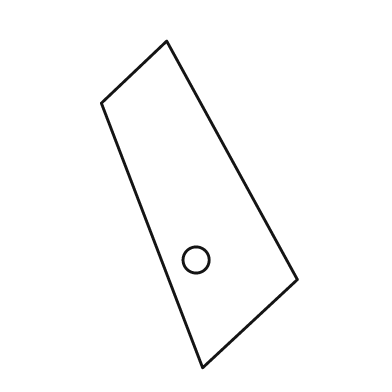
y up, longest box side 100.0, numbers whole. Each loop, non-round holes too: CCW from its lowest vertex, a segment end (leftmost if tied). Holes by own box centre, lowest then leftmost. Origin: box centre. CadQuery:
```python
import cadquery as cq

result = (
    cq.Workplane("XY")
    .moveTo(1.0, -50.0)
    .lineTo(30.0, -23.0)
    .lineTo(-10.0, 50.0)
    .lineTo(-30.0, 31.0)
    .close()
    .moveTo(-1.0, -17.0)
    .circle(4.0)
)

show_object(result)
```